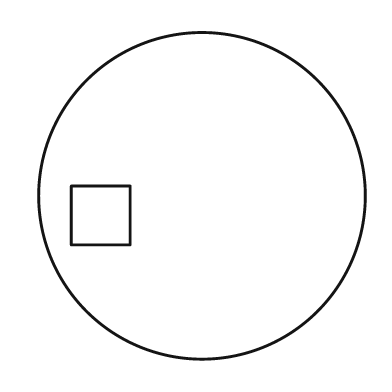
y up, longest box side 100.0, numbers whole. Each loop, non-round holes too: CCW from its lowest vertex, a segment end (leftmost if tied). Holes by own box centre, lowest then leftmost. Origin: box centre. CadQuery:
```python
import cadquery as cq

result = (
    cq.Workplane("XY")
    .moveTo(0.0, 0.0)
    .circle(50.0)
    .moveTo(-40.0, -15.0)
    .lineTo(-22.0, -15.0)
    .lineTo(-22.0, 3.0)
    .lineTo(-40.0, 3.0)
    .close()
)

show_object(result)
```